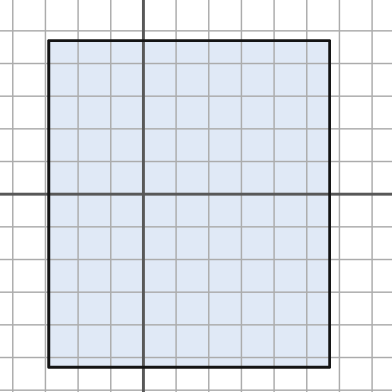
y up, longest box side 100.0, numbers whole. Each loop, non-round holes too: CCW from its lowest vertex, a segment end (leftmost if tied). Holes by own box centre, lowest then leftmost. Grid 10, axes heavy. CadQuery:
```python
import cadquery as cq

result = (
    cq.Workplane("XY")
    .moveTo(-29.0, -53.0)
    .lineTo(57.0, -53.0)
    .lineTo(57.0, 47.0)
    .lineTo(-29.0, 47.0)
    .close()
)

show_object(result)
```